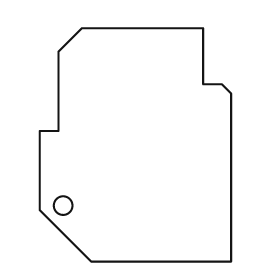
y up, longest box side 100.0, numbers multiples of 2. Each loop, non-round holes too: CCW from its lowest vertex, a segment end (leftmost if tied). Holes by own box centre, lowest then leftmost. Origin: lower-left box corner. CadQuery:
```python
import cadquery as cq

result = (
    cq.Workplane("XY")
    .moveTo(22.0, 0.0)
    .lineTo(82.0, 0.0)
    .lineTo(82.0, 72.0)
    .lineTo(78.0, 76.0)
    .lineTo(70.0, 76.0)
    .lineTo(70.0, 100.0)
    .lineTo(18.0, 100.0)
    .lineTo(8.0, 90.0)
    .lineTo(8.0, 56.0)
    .lineTo(0.0, 56.0)
    .lineTo(0.0, 22.0)
    .close()
    .moveTo(10.0, 24.0)
    .circle(4.0)
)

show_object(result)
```